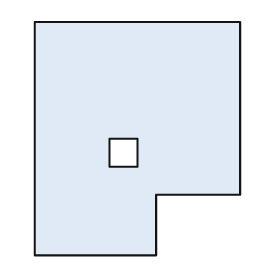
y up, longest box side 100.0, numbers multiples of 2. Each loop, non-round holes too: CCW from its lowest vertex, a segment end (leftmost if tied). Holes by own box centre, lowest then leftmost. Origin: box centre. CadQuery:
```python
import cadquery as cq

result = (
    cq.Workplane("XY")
    .moveTo(-44.0, -50.0)
    .lineTo(8.0, -50.0)
    .lineTo(8.0, -24.0)
    .lineTo(44.0, -24.0)
    .lineTo(44.0, 50.0)
    .lineTo(-44.0, 50.0)
    .close()
    .moveTo(-12.0, -12.0)
    .lineTo(0.0, -12.0)
    .lineTo(0.0, 0.0)
    .lineTo(-12.0, 0.0)
    .close()
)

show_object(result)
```